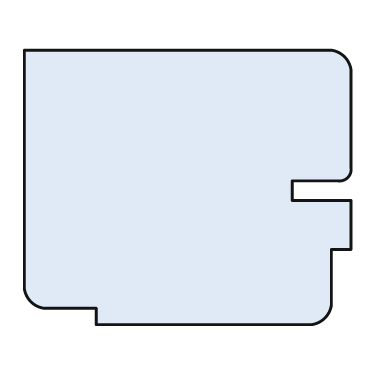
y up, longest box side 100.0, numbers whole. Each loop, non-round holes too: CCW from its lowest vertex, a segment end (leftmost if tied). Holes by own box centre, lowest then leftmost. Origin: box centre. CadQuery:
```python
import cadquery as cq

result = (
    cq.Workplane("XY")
    .moveTo(-28.0, -42.0)
    .lineTo(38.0, -42.0)
    .threePointArc((42.0, -40.0), (44.0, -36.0))
    .lineTo(44.0, -19.0)
    .lineTo(50.0, -19.0)
    .lineTo(50.0, -4.0)
    .lineTo(32.0, -4.0)
    .lineTo(32.0, 2.0)
    .lineTo(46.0, 2.0)
    .threePointArc((49.0, 3.0), (50.0, 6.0))
    .lineTo(50.0, 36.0)
    .threePointArc((48.0, 40.0), (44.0, 42.0))
    .lineTo(-50.0, 42.0)
    .lineTo(-50.0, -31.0)
    .threePointArc((-48.0, -35.0), (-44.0, -37.0))
    .lineTo(-28.0, -37.0)
    .close()
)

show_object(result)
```